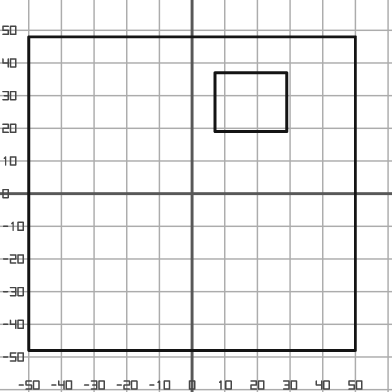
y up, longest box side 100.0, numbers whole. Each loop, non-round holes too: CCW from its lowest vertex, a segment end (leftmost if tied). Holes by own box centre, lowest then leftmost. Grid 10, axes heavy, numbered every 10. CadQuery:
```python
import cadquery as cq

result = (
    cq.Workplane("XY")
    .moveTo(-50.0, -48.0)
    .lineTo(50.0, -48.0)
    .lineTo(50.0, 48.0)
    .lineTo(-50.0, 48.0)
    .close()
    .moveTo(7.0, 19.0)
    .lineTo(29.0, 19.0)
    .lineTo(29.0, 37.0)
    .lineTo(7.0, 37.0)
    .close()
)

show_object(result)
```